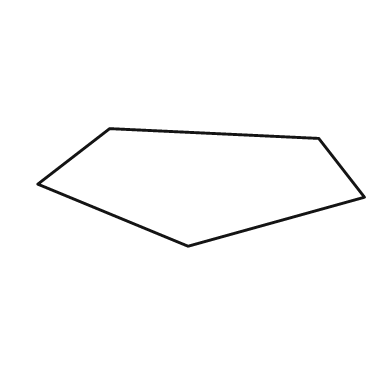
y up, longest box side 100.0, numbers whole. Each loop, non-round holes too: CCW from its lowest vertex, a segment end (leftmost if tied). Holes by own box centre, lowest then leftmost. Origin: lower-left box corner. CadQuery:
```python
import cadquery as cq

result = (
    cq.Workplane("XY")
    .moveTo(46.0, 0.0)
    .lineTo(100.0, 15.0)
    .lineTo(86.0, 33.0)
    .lineTo(22.0, 36.0)
    .lineTo(0.0, 19.0)
    .close()
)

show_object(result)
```